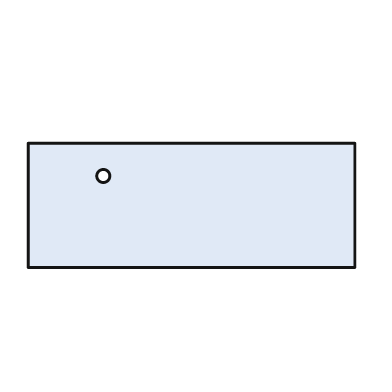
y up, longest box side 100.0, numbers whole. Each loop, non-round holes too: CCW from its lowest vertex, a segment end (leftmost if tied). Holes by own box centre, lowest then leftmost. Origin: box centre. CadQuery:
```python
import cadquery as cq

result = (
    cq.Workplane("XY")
    .moveTo(-50.0, -19.0)
    .lineTo(50.0, -19.0)
    .lineTo(50.0, 19.0)
    .lineTo(-50.0, 19.0)
    .close()
    .moveTo(-27.0, 9.0)
    .circle(2.0)
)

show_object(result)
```